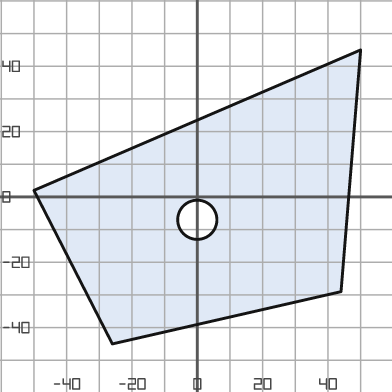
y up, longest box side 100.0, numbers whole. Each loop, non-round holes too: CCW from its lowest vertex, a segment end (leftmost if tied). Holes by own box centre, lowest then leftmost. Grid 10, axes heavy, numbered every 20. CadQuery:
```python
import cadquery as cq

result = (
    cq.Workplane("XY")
    .moveTo(-26.0, -45.0)
    .lineTo(44.0, -29.0)
    .lineTo(50.0, 45.0)
    .lineTo(-50.0, 2.0)
    .close()
    .moveTo(0.0, -7.0)
    .circle(6.0)
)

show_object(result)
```